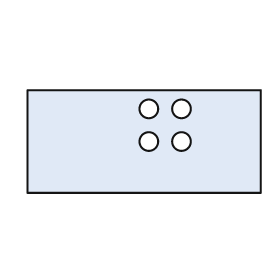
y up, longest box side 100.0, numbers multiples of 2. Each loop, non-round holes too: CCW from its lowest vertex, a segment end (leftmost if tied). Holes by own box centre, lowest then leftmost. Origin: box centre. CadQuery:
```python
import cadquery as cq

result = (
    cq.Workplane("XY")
    .moveTo(-50.0, -22.0)
    .lineTo(50.0, -22.0)
    .lineTo(50.0, 22.0)
    .lineTo(-50.0, 22.0)
    .close()
    .moveTo(2.0, 0.0)
    .circle(4.0)
    .moveTo(16.0, 0.0)
    .circle(4.0)
    .moveTo(2.0, 14.0)
    .circle(4.0)
    .moveTo(16.0, 14.0)
    .circle(4.0)
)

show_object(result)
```